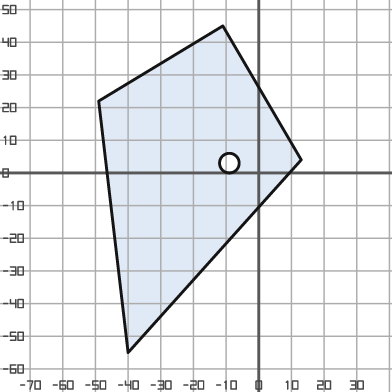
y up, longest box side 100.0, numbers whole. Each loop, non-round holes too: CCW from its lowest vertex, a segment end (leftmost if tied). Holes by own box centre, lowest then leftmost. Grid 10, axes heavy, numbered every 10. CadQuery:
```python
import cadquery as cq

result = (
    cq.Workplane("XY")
    .moveTo(-40.0, -55.0)
    .lineTo(13.0, 4.0)
    .lineTo(-11.0, 45.0)
    .lineTo(-49.0, 22.0)
    .close()
    .moveTo(-9.0, 3.0)
    .circle(3.0)
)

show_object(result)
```